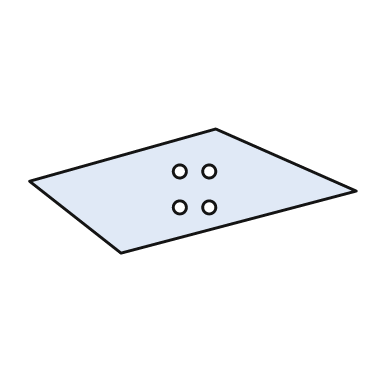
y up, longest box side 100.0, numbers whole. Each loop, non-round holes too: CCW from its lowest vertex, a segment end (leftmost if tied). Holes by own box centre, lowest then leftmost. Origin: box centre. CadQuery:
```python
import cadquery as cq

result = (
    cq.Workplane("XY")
    .moveTo(-22.0, -19.0)
    .lineTo(50.0, 0.0)
    .lineTo(7.0, 19.0)
    .lineTo(-50.0, 3.0)
    .close()
    .moveTo(-4.0, -5.0)
    .circle(2.0)
    .moveTo(5.0, -5.0)
    .circle(2.0)
    .moveTo(-4.0, 6.0)
    .circle(2.0)
    .moveTo(5.0, 6.0)
    .circle(2.0)
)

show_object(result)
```